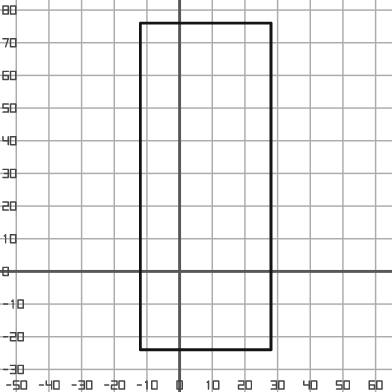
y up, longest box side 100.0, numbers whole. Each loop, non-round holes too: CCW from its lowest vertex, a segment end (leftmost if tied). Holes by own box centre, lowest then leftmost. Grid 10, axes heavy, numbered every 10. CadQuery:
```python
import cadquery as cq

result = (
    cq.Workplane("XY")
    .moveTo(-12.0, -24.0)
    .lineTo(28.0, -24.0)
    .lineTo(28.0, 76.0)
    .lineTo(-12.0, 76.0)
    .close()
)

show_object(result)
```